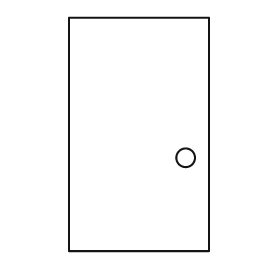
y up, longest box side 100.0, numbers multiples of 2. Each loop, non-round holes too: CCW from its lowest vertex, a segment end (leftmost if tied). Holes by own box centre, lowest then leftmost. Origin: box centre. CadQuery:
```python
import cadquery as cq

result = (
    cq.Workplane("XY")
    .moveTo(-30.0, -50.0)
    .lineTo(30.0, -50.0)
    .lineTo(30.0, 50.0)
    .lineTo(-30.0, 50.0)
    .close()
    .moveTo(20.0, -10.0)
    .circle(4.0)
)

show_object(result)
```